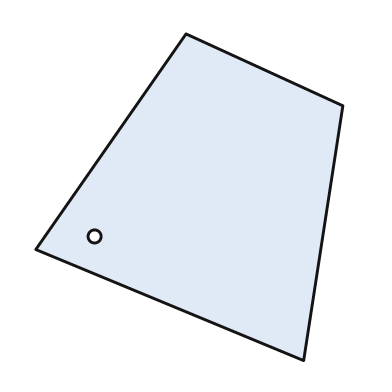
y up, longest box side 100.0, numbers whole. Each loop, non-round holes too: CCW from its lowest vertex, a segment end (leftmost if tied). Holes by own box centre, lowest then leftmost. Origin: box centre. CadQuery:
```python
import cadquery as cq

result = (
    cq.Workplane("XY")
    .moveTo(35.0, -50.0)
    .lineTo(47.0, 28.0)
    .lineTo(-1.0, 50.0)
    .lineTo(-47.0, -16.0)
    .close()
    .moveTo(-29.0, -12.0)
    .circle(2.0)
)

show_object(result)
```